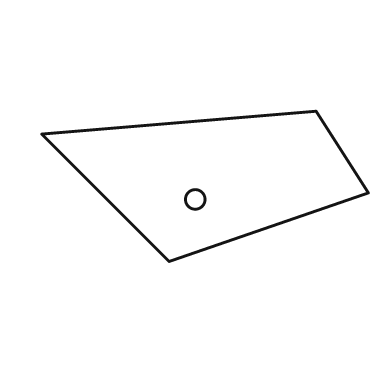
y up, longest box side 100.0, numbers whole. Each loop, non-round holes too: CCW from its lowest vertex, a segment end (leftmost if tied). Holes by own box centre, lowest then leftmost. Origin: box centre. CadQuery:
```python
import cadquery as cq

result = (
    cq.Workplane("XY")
    .moveTo(-11.0, -23.0)
    .lineTo(50.0, -2.0)
    .lineTo(34.0, 23.0)
    .lineTo(-50.0, 16.0)
    .close()
    .moveTo(-3.0, -4.0)
    .circle(3.0)
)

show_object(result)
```